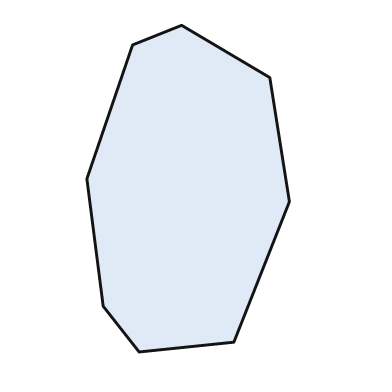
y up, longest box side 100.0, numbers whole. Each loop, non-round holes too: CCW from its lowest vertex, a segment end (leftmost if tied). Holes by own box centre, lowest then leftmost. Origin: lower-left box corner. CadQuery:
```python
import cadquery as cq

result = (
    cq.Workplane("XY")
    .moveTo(16.0, 0.0)
    .lineTo(45.0, 3.0)
    .lineTo(62.0, 46.0)
    .lineTo(56.0, 84.0)
    .lineTo(29.0, 100.0)
    .lineTo(14.0, 94.0)
    .lineTo(0.0, 53.0)
    .lineTo(5.0, 14.0)
    .close()
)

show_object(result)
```